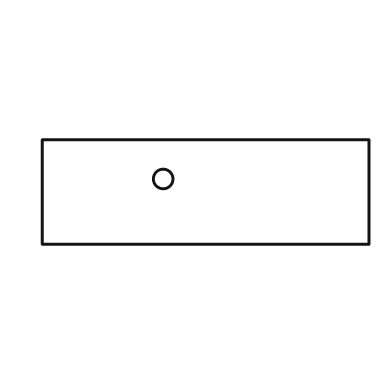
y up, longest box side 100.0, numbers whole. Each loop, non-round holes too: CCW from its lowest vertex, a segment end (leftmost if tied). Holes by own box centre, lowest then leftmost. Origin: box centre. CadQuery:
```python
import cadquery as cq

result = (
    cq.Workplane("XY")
    .moveTo(-50.0, -16.0)
    .lineTo(50.0, -16.0)
    .lineTo(50.0, 16.0)
    .lineTo(-50.0, 16.0)
    .close()
    .moveTo(-13.0, 4.0)
    .circle(3.0)
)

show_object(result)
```